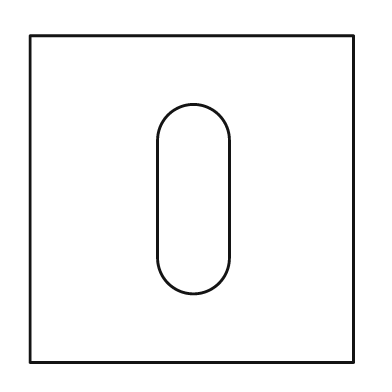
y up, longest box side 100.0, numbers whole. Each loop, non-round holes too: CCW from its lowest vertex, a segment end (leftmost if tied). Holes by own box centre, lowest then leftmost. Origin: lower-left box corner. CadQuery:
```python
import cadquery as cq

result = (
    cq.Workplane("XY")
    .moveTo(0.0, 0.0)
    .lineTo(99.0, 0.0)
    .lineTo(99.0, 100.0)
    .lineTo(0.0, 100.0)
    .close()
    .moveTo(39.0, 32.0)
    .threePointArc((50.0, 21.0), (61.0, 32.0))
    .lineTo(61.0, 68.0)
    .threePointArc((50.0, 79.0), (39.0, 68.0))
    .close()
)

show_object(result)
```